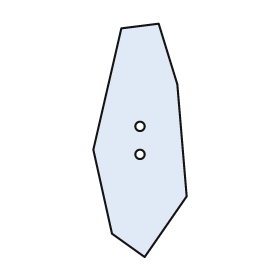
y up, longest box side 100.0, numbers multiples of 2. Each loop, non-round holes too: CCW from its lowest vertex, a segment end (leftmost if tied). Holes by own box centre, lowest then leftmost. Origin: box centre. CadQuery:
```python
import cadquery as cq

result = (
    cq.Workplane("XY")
    .moveTo(2.0, -50.0)
    .lineTo(20.0, -24.0)
    .lineTo(16.0, 24.0)
    .lineTo(8.0, 50.0)
    .lineTo(-8.0, 48.0)
    .lineTo(-20.0, -4.0)
    .lineTo(-12.0, -40.0)
    .close()
    .moveTo(0.0, -6.0)
    .circle(2.0)
    .moveTo(0.0, 6.0)
    .circle(2.0)
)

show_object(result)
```